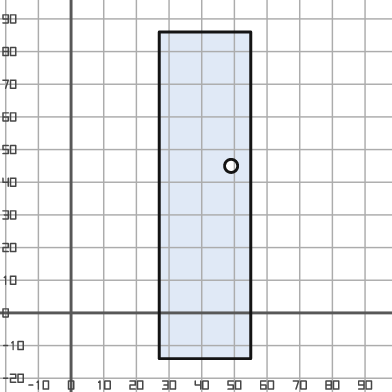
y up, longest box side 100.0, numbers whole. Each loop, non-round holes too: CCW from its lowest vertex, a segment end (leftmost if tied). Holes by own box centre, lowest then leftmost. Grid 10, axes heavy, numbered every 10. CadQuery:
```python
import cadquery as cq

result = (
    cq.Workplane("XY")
    .moveTo(27.0, -14.0)
    .lineTo(55.0, -14.0)
    .lineTo(55.0, 86.0)
    .lineTo(27.0, 86.0)
    .close()
    .moveTo(49.0, 45.0)
    .circle(2.0)
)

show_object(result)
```